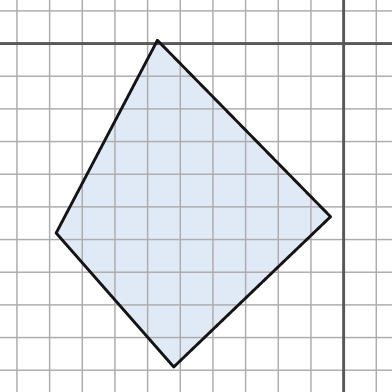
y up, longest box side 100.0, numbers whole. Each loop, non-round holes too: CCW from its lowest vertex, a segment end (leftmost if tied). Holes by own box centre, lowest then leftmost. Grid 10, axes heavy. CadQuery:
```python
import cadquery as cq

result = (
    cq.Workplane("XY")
    .moveTo(-52.0, -99.0)
    .lineTo(-4.0, -53.0)
    .lineTo(-57.0, 1.0)
    .lineTo(-88.0, -58.0)
    .close()
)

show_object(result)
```